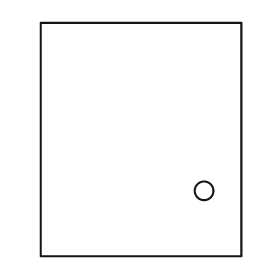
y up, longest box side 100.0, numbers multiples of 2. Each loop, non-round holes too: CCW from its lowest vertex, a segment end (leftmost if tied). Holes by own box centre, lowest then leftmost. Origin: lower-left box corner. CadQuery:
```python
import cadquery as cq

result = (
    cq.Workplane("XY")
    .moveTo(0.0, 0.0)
    .lineTo(86.0, 0.0)
    .lineTo(86.0, 100.0)
    .lineTo(0.0, 100.0)
    .close()
    .moveTo(70.0, 28.0)
    .circle(4.0)
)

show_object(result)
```